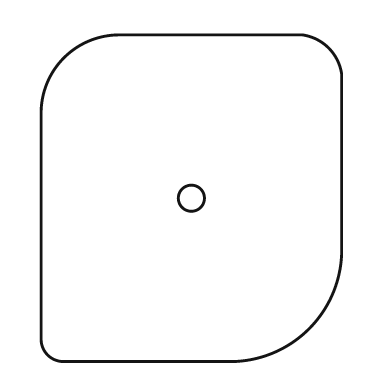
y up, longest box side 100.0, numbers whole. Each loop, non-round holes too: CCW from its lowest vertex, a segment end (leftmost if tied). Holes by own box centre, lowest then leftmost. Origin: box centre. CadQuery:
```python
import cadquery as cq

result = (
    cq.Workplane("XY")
    .moveTo(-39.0, -50.0)
    .lineTo(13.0, -50.0)
    .threePointArc((36.0, -40.0), (46.0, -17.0))
    .lineTo(46.0, 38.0)
    .threePointArc((42.0, 46.0), (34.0, 50.0))
    .lineTo(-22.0, 50.0)
    .threePointArc((-39.0, 43.0), (-46.0, 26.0))
    .lineTo(-46.0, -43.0)
    .threePointArc((-44.0, -48.0), (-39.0, -50.0))
    .close()
    .moveTo(0.0, 0.0)
    .circle(4.0)
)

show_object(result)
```